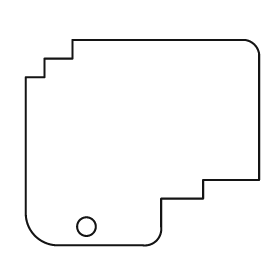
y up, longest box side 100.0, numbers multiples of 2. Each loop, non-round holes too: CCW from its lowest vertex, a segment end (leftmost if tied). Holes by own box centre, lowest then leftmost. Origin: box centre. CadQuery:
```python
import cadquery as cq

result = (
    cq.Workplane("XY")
    .moveTo(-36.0, -44.0)
    .lineTo(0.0, -44.0)
    .threePointArc((6.0, -42.0), (8.0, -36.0))
    .lineTo(8.0, -24.0)
    .lineTo(26.0, -24.0)
    .lineTo(26.0, -16.0)
    .lineTo(50.0, -16.0)
    .lineTo(50.0, 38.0)
    .threePointArc((48.0, 42.0), (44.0, 44.0))
    .lineTo(-30.0, 44.0)
    .lineTo(-30.0, 36.0)
    .lineTo(-42.0, 36.0)
    .lineTo(-42.0, 28.0)
    .lineTo(-50.0, 28.0)
    .lineTo(-50.0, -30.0)
    .threePointArc((-46.0, -40.0), (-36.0, -44.0))
    .close()
    .moveTo(-24.0, -36.0)
    .circle(4.0)
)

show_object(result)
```